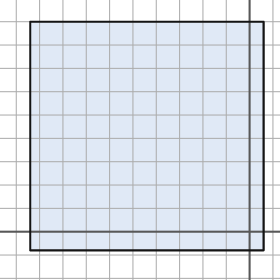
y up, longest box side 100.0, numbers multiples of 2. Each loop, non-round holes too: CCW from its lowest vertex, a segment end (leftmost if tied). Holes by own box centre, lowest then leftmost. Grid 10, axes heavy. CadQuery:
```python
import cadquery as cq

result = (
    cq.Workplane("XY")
    .moveTo(-94.0, -8.0)
    .lineTo(6.0, -8.0)
    .lineTo(6.0, 90.0)
    .lineTo(-94.0, 90.0)
    .close()
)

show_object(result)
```